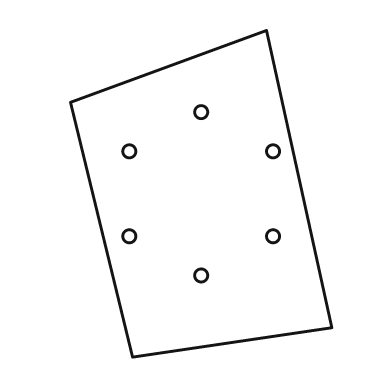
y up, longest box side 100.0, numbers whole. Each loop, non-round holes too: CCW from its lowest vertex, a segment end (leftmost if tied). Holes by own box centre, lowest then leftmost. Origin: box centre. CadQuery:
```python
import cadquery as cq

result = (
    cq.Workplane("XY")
    .moveTo(-21.0, -50.0)
    .lineTo(40.0, -41.0)
    .lineTo(20.0, 50.0)
    .lineTo(-40.0, 28.0)
    .close()
    .moveTo(0.0, -25.0)
    .circle(2.0)
    .moveTo(-22.0, -13.0)
    .circle(2.0)
    .moveTo(22.0, -13.0)
    .circle(2.0)
    .moveTo(-22.0, 13.0)
    .circle(2.0)
    .moveTo(22.0, 13.0)
    .circle(2.0)
    .moveTo(0.0, 25.0)
    .circle(2.0)
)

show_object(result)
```